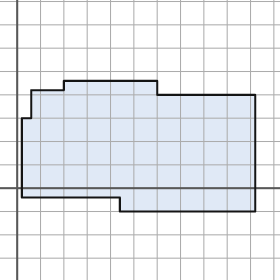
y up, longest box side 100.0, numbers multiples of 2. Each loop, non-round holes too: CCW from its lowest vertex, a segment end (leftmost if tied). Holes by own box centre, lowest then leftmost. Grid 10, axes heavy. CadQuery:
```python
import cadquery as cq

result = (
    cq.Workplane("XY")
    .moveTo(44.0, -10.0)
    .lineTo(102.0, -10.0)
    .lineTo(102.0, 40.0)
    .lineTo(60.0, 40.0)
    .lineTo(60.0, 46.0)
    .lineTo(20.0, 46.0)
    .lineTo(20.0, 42.0)
    .lineTo(6.0, 42.0)
    .lineTo(6.0, 30.0)
    .lineTo(2.0, 30.0)
    .lineTo(2.0, -4.0)
    .lineTo(44.0, -4.0)
    .close()
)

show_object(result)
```